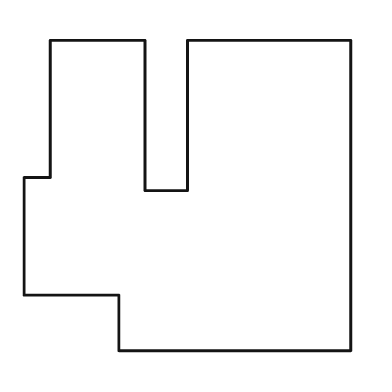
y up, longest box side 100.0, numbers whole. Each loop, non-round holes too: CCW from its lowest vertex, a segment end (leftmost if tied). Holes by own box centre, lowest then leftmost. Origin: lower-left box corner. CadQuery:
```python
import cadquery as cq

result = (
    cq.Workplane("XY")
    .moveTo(29.0, 0.0)
    .lineTo(100.0, 0.0)
    .lineTo(100.0, 95.0)
    .lineTo(50.0, 95.0)
    .lineTo(50.0, 49.0)
    .lineTo(37.0, 49.0)
    .lineTo(37.0, 95.0)
    .lineTo(8.0, 95.0)
    .lineTo(8.0, 53.0)
    .lineTo(0.0, 53.0)
    .lineTo(0.0, 17.0)
    .lineTo(29.0, 17.0)
    .close()
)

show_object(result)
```